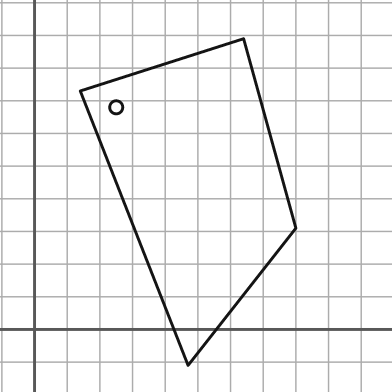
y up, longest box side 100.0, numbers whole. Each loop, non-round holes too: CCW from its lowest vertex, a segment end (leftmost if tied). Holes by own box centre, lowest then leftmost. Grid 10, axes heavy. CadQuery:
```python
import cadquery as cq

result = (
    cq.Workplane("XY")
    .moveTo(47.0, -11.0)
    .lineTo(80.0, 31.0)
    .lineTo(64.0, 89.0)
    .lineTo(14.0, 73.0)
    .close()
    .moveTo(25.0, 68.0)
    .circle(2.0)
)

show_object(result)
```